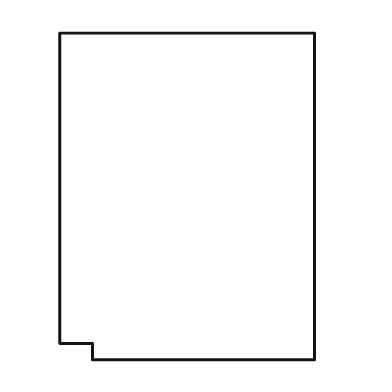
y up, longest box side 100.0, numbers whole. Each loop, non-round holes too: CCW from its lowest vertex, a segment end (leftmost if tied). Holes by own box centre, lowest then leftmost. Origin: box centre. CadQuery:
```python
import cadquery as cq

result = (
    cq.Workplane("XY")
    .moveTo(-29.0, -50.0)
    .lineTo(39.0, -50.0)
    .lineTo(39.0, 50.0)
    .lineTo(-39.0, 50.0)
    .lineTo(-39.0, -45.0)
    .lineTo(-29.0, -45.0)
    .close()
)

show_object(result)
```